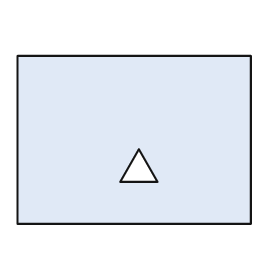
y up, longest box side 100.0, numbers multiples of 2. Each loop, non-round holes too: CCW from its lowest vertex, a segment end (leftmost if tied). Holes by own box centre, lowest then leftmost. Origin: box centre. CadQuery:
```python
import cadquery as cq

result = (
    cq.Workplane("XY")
    .moveTo(-50.0, -36.0)
    .lineTo(50.0, -36.0)
    .lineTo(50.0, 36.0)
    .lineTo(-50.0, 36.0)
    .close()
    .moveTo(-6.0, -18.0)
    .lineTo(10.0, -18.0)
    .lineTo(2.0, -4.0)
    .close()
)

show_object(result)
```